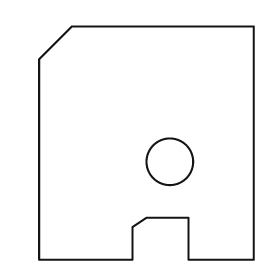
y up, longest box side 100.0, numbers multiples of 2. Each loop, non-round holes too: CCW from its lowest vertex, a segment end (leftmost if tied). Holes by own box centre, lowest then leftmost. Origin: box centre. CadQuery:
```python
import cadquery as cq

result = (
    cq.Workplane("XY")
    .moveTo(-46.0, -50.0)
    .lineTo(-6.0, -50.0)
    .lineTo(-6.0, -36.0)
    .lineTo(0.0, -32.0)
    .lineTo(18.0, -32.0)
    .lineTo(18.0, -50.0)
    .lineTo(46.0, -50.0)
    .lineTo(46.0, 50.0)
    .lineTo(-32.0, 50.0)
    .lineTo(-46.0, 36.0)
    .close()
    .moveTo(10.0, -8.0)
    .circle(10.0)
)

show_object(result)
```